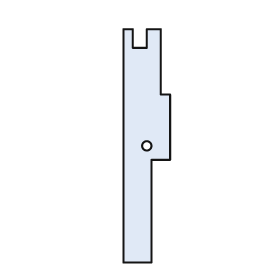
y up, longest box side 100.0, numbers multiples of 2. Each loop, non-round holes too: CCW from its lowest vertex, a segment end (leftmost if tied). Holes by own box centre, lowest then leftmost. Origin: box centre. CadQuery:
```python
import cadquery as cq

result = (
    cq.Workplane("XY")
    .moveTo(-10.0, -50.0)
    .lineTo(2.0, -50.0)
    .lineTo(2.0, -6.0)
    .lineTo(10.0, -6.0)
    .lineTo(10.0, 22.0)
    .lineTo(6.0, 22.0)
    .lineTo(6.0, 50.0)
    .lineTo(0.0, 50.0)
    .lineTo(0.0, 42.0)
    .lineTo(-6.0, 42.0)
    .lineTo(-6.0, 50.0)
    .lineTo(-10.0, 50.0)
    .close()
    .moveTo(0.0, 0.0)
    .circle(2.0)
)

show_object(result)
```